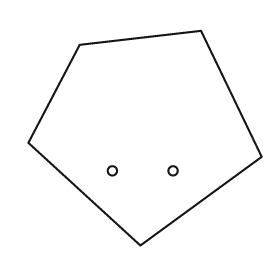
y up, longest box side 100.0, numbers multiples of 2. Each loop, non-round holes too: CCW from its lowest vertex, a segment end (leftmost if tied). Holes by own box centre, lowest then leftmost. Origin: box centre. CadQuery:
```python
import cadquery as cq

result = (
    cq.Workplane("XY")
    .moveTo(-2.0, -46.0)
    .lineTo(50.0, -8.0)
    .lineTo(24.0, 46.0)
    .lineTo(-28.0, 40.0)
    .lineTo(-50.0, -2.0)
    .close()
    .moveTo(-14.0, -14.0)
    .circle(2.0)
    .moveTo(12.0, -14.0)
    .circle(2.0)
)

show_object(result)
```